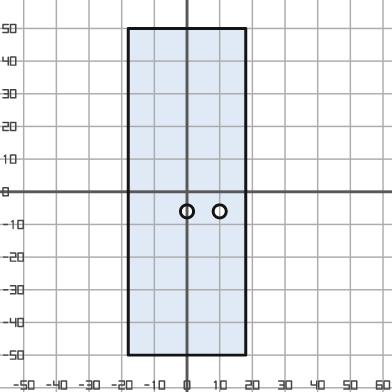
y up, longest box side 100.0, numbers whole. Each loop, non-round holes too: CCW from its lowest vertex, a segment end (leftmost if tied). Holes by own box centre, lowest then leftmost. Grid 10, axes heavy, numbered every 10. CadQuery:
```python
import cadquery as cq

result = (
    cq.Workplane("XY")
    .moveTo(-18.0, -50.0)
    .lineTo(18.0, -50.0)
    .lineTo(18.0, 50.0)
    .lineTo(-18.0, 50.0)
    .close()
    .moveTo(0.0, -6.0)
    .circle(2.0)
    .moveTo(10.0, -6.0)
    .circle(2.0)
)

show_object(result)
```